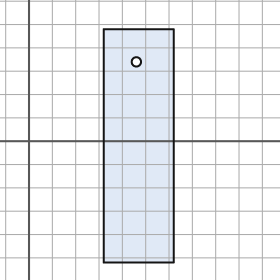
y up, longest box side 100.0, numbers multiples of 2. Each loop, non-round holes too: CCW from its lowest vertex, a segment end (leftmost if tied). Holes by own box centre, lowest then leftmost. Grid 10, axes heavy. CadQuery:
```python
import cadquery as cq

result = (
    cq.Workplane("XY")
    .moveTo(32.0, -52.0)
    .lineTo(62.0, -52.0)
    .lineTo(62.0, 48.0)
    .lineTo(32.0, 48.0)
    .close()
    .moveTo(46.0, 34.0)
    .circle(2.0)
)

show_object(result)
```